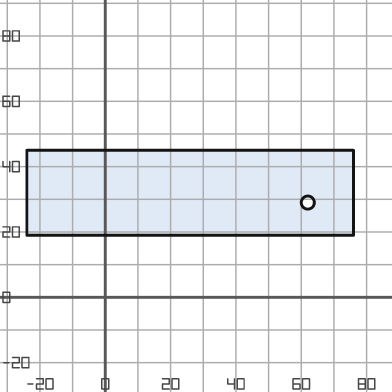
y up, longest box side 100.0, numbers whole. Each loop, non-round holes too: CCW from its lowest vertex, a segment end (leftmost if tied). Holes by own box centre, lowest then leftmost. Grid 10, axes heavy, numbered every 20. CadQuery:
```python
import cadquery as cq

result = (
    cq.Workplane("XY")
    .moveTo(-24.0, 19.0)
    .lineTo(76.0, 19.0)
    .lineTo(76.0, 45.0)
    .lineTo(-24.0, 45.0)
    .close()
    .moveTo(62.0, 29.0)
    .circle(2.0)
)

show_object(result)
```